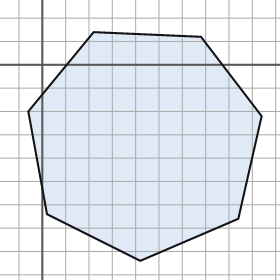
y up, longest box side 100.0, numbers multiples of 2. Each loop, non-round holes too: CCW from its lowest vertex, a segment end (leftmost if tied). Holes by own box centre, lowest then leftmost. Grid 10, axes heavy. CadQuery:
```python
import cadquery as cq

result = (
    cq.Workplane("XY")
    .moveTo(42.0, -84.0)
    .lineTo(84.0, -66.0)
    .lineTo(94.0, -22.0)
    .lineTo(68.0, 12.0)
    .lineTo(22.0, 14.0)
    .lineTo(-6.0, -20.0)
    .lineTo(2.0, -64.0)
    .close()
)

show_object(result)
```